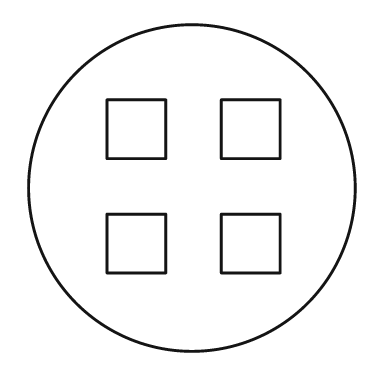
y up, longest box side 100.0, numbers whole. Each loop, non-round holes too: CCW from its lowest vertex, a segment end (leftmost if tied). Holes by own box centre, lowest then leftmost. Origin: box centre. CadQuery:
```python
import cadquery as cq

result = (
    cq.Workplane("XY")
    .moveTo(0.0, 0.0)
    .circle(50.0)
    .moveTo(-26.0, -26.0)
    .lineTo(-8.0, -26.0)
    .lineTo(-8.0, -8.0)
    .lineTo(-26.0, -8.0)
    .close()
    .moveTo(9.0, -26.0)
    .lineTo(27.0, -26.0)
    .lineTo(27.0, -8.0)
    .lineTo(9.0, -8.0)
    .close()
    .moveTo(-26.0, 9.0)
    .lineTo(-8.0, 9.0)
    .lineTo(-8.0, 27.0)
    .lineTo(-26.0, 27.0)
    .close()
    .moveTo(9.0, 9.0)
    .lineTo(27.0, 9.0)
    .lineTo(27.0, 27.0)
    .lineTo(9.0, 27.0)
    .close()
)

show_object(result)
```